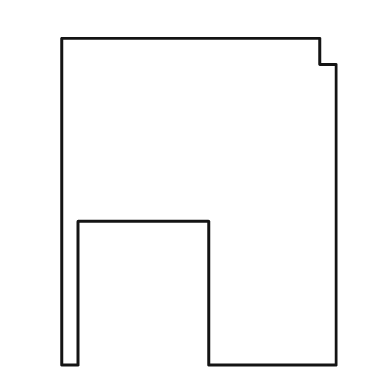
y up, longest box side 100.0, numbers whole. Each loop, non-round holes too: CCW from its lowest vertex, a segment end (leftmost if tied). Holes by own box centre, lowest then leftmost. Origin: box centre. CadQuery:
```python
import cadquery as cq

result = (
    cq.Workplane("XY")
    .moveTo(-42.0, -50.0)
    .lineTo(-37.0, -50.0)
    .lineTo(-37.0, -6.0)
    .lineTo(3.0, -6.0)
    .lineTo(3.0, -50.0)
    .lineTo(42.0, -50.0)
    .lineTo(42.0, 42.0)
    .lineTo(37.0, 42.0)
    .lineTo(37.0, 50.0)
    .lineTo(-42.0, 50.0)
    .close()
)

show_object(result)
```